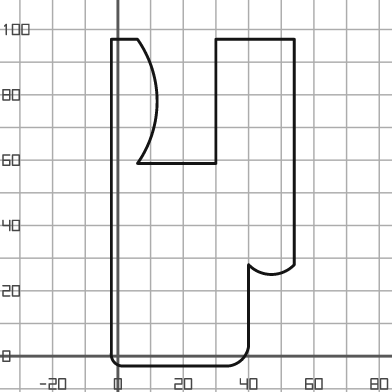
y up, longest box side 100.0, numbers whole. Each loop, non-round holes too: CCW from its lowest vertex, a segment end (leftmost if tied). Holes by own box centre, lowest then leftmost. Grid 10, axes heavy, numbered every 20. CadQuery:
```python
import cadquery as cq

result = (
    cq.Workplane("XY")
    .moveTo(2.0, -3.0)
    .lineTo(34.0, -3.0)
    .threePointArc((38.0, -1.0), (40.0, 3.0))
    .lineTo(40.0, 28.0)
    .threePointArc((47.0, 25.0), (54.0, 28.0))
    .lineTo(54.0, 97.0)
    .lineTo(30.0, 97.0)
    .lineTo(30.0, 59.0)
    .lineTo(6.0, 59.0)
    .threePointArc((12.0, 78.0), (6.0, 97.0))
    .lineTo(-2.0, 97.0)
    .lineTo(-2.0, 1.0)
    .threePointArc((-1.0, -2.0), (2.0, -3.0))
    .close()
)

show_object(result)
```